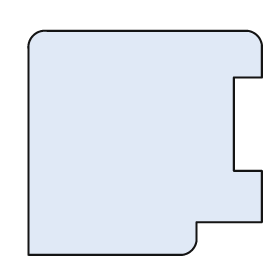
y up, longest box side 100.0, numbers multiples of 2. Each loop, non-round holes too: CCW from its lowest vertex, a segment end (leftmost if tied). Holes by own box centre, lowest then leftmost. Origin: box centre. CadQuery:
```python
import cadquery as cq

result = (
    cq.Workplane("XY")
    .moveTo(-50.0, -48.0)
    .lineTo(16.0, -48.0)
    .threePointArc((20.0, -46.0), (22.0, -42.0))
    .lineTo(22.0, -34.0)
    .lineTo(50.0, -34.0)
    .lineTo(50.0, -12.0)
    .lineTo(38.0, -12.0)
    .lineTo(38.0, 28.0)
    .lineTo(50.0, 28.0)
    .lineTo(50.0, 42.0)
    .threePointArc((48.0, 46.0), (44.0, 48.0))
    .lineTo(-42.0, 48.0)
    .threePointArc((-48.0, 46.0), (-50.0, 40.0))
    .close()
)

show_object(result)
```